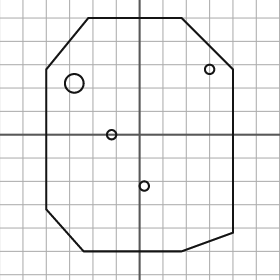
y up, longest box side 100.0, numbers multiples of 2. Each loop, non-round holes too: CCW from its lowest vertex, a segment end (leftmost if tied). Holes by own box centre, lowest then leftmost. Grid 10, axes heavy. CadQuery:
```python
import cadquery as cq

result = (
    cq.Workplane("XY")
    .moveTo(-24.0, -50.0)
    .lineTo(18.0, -50.0)
    .lineTo(40.0, -42.0)
    .lineTo(40.0, 28.0)
    .lineTo(18.0, 50.0)
    .lineTo(-22.0, 50.0)
    .lineTo(-40.0, 28.0)
    .lineTo(-40.0, -32.0)
    .close()
    .moveTo(2.0, -22.0)
    .circle(2.0)
    .moveTo(-12.0, 0.0)
    .circle(2.0)
    .moveTo(-28.0, 22.0)
    .circle(4.0)
    .moveTo(30.0, 28.0)
    .circle(2.0)
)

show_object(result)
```